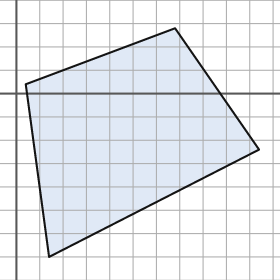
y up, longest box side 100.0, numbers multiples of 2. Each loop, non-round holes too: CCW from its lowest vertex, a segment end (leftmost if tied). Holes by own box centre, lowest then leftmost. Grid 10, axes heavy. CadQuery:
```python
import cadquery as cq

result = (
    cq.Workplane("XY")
    .moveTo(14.0, -70.0)
    .lineTo(104.0, -24.0)
    .lineTo(68.0, 28.0)
    .lineTo(4.0, 4.0)
    .close()
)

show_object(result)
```